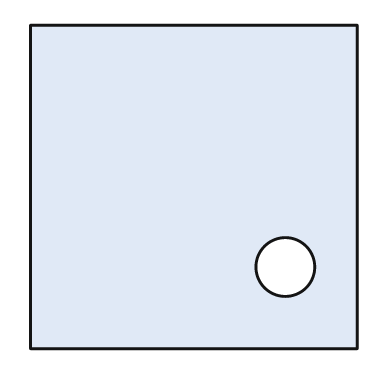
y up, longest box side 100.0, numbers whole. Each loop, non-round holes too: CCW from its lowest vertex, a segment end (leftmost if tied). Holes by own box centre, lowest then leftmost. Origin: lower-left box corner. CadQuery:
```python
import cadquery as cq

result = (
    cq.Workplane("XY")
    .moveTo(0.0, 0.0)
    .lineTo(100.0, 0.0)
    .lineTo(100.0, 99.0)
    .lineTo(0.0, 99.0)
    .close()
    .moveTo(78.0, 25.0)
    .circle(9.0)
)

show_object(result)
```